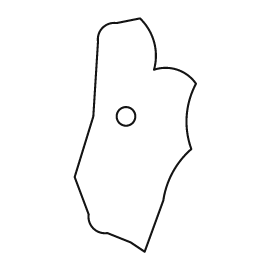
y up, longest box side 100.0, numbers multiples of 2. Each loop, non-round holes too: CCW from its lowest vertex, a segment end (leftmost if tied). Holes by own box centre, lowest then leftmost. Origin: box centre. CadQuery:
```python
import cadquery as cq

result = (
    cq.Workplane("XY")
    .moveTo(4.0, -50.0)
    .lineTo(12.0, -28.0)
    .threePointArc((16.0, -16.0), (24.0, -6.0))
    .threePointArc((22.0, 8.0), (26.0, 22.0))
    .threePointArc((18.0, 28.0), (8.0, 28.0))
    .threePointArc((8.0, 40.0), (2.0, 50.0))
    .lineTo(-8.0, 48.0)
    .threePointArc((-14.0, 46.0), (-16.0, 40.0))
    .lineTo(-18.0, 8.0)
    .lineTo(-26.0, -18.0)
    .lineTo(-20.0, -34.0)
    .threePointArc((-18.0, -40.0), (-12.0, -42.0))
    .lineTo(-2.0, -46.0)
    .close()
    .moveTo(-4.0, 8.0)
    .circle(4.0)
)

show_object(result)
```